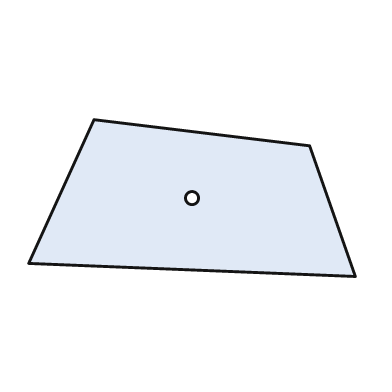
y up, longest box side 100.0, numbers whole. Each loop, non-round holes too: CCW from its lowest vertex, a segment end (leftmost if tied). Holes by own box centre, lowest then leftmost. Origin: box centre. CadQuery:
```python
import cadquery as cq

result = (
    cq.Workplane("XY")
    .moveTo(50.0, -24.0)
    .lineTo(36.0, 16.0)
    .lineTo(-30.0, 24.0)
    .lineTo(-50.0, -20.0)
    .close()
    .moveTo(0.0, 0.0)
    .circle(2.0)
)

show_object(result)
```